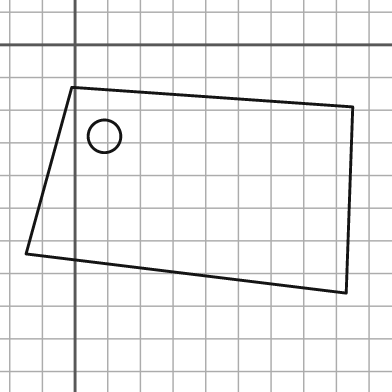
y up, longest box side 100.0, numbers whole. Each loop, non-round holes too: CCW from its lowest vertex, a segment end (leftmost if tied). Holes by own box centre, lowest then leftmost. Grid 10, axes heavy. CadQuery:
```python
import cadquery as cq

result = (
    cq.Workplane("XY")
    .moveTo(83.0, -76.0)
    .lineTo(85.0, -19.0)
    .lineTo(-1.0, -13.0)
    .lineTo(-15.0, -64.0)
    .close()
    .moveTo(9.0, -28.0)
    .circle(5.0)
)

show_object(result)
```